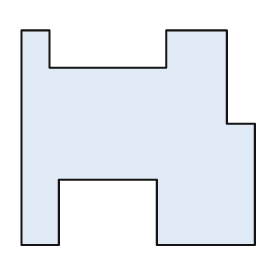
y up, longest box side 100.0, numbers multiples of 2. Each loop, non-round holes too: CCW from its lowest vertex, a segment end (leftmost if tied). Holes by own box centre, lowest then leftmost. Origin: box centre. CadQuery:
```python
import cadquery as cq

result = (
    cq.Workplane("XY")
    .moveTo(-50.0, -46.0)
    .lineTo(-34.0, -46.0)
    .lineTo(-34.0, -18.0)
    .lineTo(8.0, -18.0)
    .lineTo(8.0, -46.0)
    .lineTo(50.0, -46.0)
    .lineTo(50.0, 6.0)
    .lineTo(38.0, 6.0)
    .lineTo(38.0, 46.0)
    .lineTo(12.0, 46.0)
    .lineTo(12.0, 30.0)
    .lineTo(-38.0, 30.0)
    .lineTo(-38.0, 46.0)
    .lineTo(-50.0, 46.0)
    .close()
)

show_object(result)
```